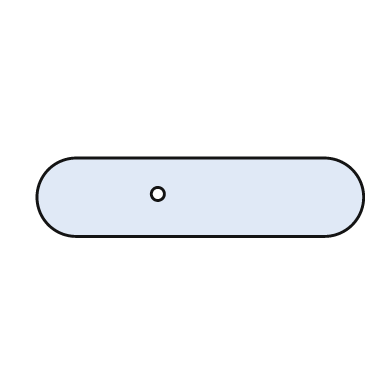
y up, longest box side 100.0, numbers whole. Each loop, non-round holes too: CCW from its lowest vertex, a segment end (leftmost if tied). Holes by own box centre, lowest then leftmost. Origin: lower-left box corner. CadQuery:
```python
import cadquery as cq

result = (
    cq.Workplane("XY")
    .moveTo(12.0, 0.0)
    .lineTo(88.0, 0.0)
    .threePointArc((100.0, 12.0), (88.0, 24.0))
    .lineTo(12.0, 24.0)
    .threePointArc((0.0, 12.0), (12.0, 0.0))
    .close()
    .moveTo(37.0, 13.0)
    .circle(2.0)
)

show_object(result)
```